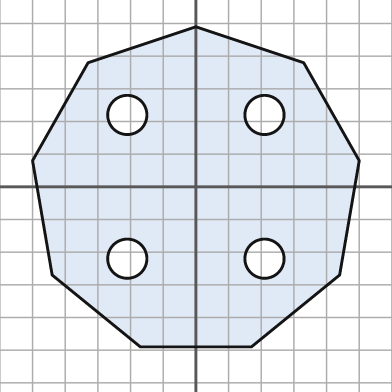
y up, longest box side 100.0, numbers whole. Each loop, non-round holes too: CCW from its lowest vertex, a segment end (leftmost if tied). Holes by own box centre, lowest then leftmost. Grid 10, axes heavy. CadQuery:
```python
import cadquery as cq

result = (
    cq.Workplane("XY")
    .moveTo(-17.0, -49.0)
    .lineTo(17.0, -49.0)
    .lineTo(44.0, -27.0)
    .lineTo(50.0, 8.0)
    .lineTo(33.0, 38.0)
    .lineTo(0.0, 49.0)
    .lineTo(-33.0, 38.0)
    .lineTo(-50.0, 8.0)
    .lineTo(-44.0, -27.0)
    .close()
    .moveTo(-21.0, -22.0)
    .circle(6.0)
    .moveTo(21.0, -22.0)
    .circle(6.0)
    .moveTo(-21.0, 22.0)
    .circle(6.0)
    .moveTo(21.0, 22.0)
    .circle(6.0)
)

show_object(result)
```